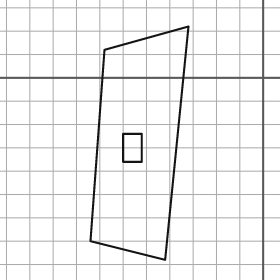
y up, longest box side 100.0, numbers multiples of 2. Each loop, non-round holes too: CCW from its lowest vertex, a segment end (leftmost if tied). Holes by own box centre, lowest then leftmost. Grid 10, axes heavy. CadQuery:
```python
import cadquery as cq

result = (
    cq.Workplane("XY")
    .moveTo(-42.0, -78.0)
    .lineTo(-32.0, 22.0)
    .lineTo(-68.0, 12.0)
    .lineTo(-74.0, -70.0)
    .close()
    .moveTo(-60.0, -36.0)
    .lineTo(-52.0, -36.0)
    .lineTo(-52.0, -24.0)
    .lineTo(-60.0, -24.0)
    .close()
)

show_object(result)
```